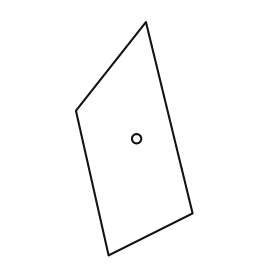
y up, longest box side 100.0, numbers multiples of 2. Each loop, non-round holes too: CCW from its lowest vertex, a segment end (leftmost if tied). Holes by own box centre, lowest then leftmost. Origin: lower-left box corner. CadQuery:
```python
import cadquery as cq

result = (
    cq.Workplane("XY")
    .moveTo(14.0, 0.0)
    .lineTo(50.0, 18.0)
    .lineTo(30.0, 100.0)
    .lineTo(0.0, 62.0)
    .close()
    .moveTo(26.0, 50.0)
    .circle(2.0)
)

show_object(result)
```